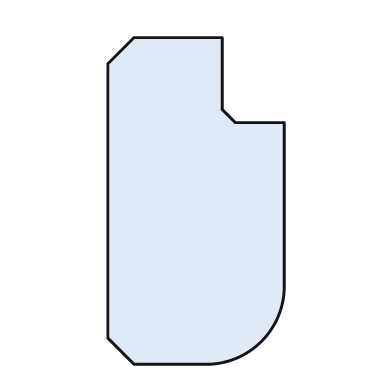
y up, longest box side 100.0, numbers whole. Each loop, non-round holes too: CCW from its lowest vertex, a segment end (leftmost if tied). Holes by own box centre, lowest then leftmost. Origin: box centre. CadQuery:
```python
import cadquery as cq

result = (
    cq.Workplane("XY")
    .moveTo(-19.0, -50.0)
    .lineTo(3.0, -50.0)
    .threePointArc((20.0, -43.0), (27.0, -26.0))
    .lineTo(27.0, 24.0)
    .lineTo(12.0, 24.0)
    .lineTo(8.0, 28.0)
    .lineTo(8.0, 50.0)
    .lineTo(-19.0, 50.0)
    .lineTo(-27.0, 42.0)
    .lineTo(-27.0, -42.0)
    .close()
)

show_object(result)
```